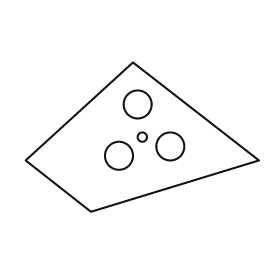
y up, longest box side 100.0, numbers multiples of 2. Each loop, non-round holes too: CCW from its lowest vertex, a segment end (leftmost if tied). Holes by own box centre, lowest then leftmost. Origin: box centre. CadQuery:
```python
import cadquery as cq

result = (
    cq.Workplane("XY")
    .moveTo(-22.0, -32.0)
    .lineTo(50.0, -10.0)
    .lineTo(-4.0, 32.0)
    .lineTo(-50.0, -10.0)
    .close()
    .moveTo(-10.0, -8.0)
    .circle(6.0)
    .moveTo(12.0, -4.0)
    .circle(6.0)
    .moveTo(0.0, 0.0)
    .circle(2.0)
    .moveTo(-2.0, 14.0)
    .circle(6.0)
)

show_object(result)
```